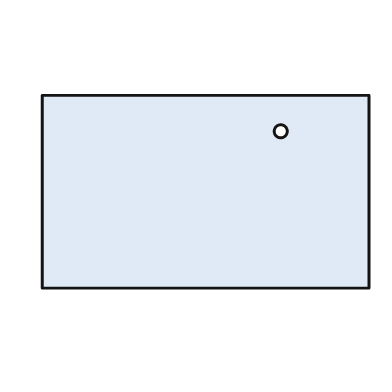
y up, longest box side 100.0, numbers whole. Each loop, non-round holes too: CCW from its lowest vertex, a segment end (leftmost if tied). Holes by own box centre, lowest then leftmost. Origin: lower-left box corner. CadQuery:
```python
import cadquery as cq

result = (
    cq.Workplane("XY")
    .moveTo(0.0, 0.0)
    .lineTo(100.0, 0.0)
    .lineTo(100.0, 59.0)
    .lineTo(0.0, 59.0)
    .close()
    .moveTo(73.0, 48.0)
    .circle(2.0)
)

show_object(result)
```